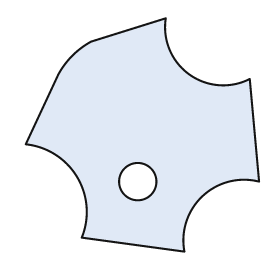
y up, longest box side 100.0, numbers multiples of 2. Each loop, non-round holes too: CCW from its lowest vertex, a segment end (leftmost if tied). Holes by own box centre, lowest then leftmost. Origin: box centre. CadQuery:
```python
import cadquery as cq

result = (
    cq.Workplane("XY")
    .moveTo(18.0, -50.0)
    .threePointArc((26.0, -26.0), (50.0, -20.0))
    .lineTo(46.0, 24.0)
    .threePointArc((20.0, 26.0), (10.0, 50.0))
    .lineTo(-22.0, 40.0)
    .threePointArc((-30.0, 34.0), (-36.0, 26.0))
    .lineTo(-50.0, -4.0)
    .threePointArc((-28.0, -18.0), (-26.0, -44.0))
    .close()
    .moveTo(-2.0, -20.0)
    .circle(8.0)
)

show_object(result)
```